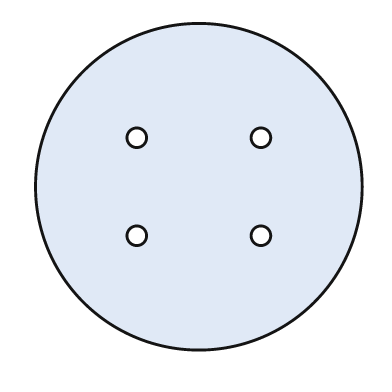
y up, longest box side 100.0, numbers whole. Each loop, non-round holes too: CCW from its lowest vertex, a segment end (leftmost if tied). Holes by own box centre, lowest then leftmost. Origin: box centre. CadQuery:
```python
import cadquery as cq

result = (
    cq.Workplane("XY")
    .moveTo(0.0, 0.0)
    .circle(50.0)
    .moveTo(-19.0, -15.0)
    .circle(3.0)
    .moveTo(19.0, -15.0)
    .circle(3.0)
    .moveTo(-19.0, 15.0)
    .circle(3.0)
    .moveTo(19.0, 15.0)
    .circle(3.0)
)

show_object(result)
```